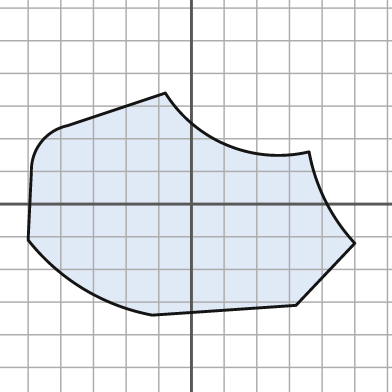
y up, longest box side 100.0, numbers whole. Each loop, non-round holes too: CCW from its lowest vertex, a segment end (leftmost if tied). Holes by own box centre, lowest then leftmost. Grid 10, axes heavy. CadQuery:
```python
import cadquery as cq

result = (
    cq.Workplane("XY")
    .moveTo(-12.0, -34.0)
    .lineTo(32.0, -31.0)
    .lineTo(50.0, -12.0)
    .threePointArc((41.0, 1.0), (36.0, 16.0))
    .threePointArc((11.0, 18.0), (-8.0, 34.0))
    .lineTo(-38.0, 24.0)
    .threePointArc((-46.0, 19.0), (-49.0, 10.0))
    .lineTo(-50.0, -11.0)
    .threePointArc((-33.0, -26.0), (-12.0, -34.0))
    .close()
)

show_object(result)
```